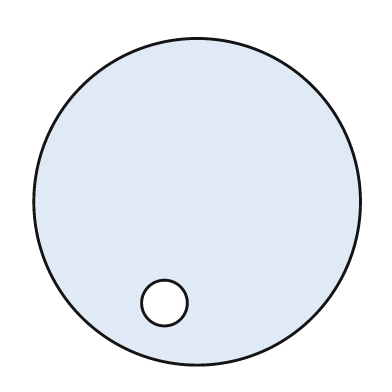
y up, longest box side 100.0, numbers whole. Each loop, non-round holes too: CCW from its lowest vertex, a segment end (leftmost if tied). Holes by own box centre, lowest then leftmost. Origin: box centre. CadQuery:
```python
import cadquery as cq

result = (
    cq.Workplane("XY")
    .moveTo(0.0, 0.0)
    .circle(50.0)
    .moveTo(-10.0, -31.0)
    .circle(7.0)
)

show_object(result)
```